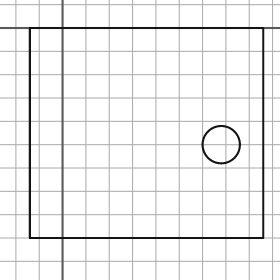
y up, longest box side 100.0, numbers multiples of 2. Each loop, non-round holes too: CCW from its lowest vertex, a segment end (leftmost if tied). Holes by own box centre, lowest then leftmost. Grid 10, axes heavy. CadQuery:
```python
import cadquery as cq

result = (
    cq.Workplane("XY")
    .moveTo(-14.0, -90.0)
    .lineTo(86.0, -90.0)
    .lineTo(86.0, 0.0)
    .lineTo(-14.0, 0.0)
    .close()
    .moveTo(68.0, -50.0)
    .circle(8.0)
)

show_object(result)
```